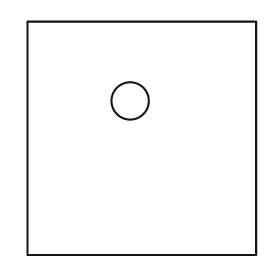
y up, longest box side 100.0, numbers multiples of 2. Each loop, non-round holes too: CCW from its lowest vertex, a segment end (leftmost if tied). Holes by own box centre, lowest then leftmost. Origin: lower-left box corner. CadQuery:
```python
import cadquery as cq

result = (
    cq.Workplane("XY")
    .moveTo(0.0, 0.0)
    .lineTo(98.0, 0.0)
    .lineTo(98.0, 100.0)
    .lineTo(0.0, 100.0)
    .close()
    .moveTo(44.0, 66.0)
    .circle(8.0)
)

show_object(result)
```